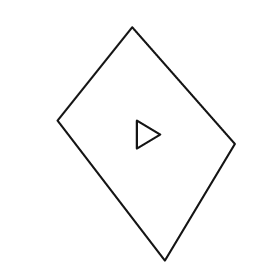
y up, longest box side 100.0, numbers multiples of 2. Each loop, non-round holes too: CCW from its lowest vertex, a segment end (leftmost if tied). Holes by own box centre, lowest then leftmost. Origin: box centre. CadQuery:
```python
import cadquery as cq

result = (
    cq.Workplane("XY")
    .moveTo(8.0, -50.0)
    .lineTo(38.0, 0.0)
    .lineTo(-6.0, 50.0)
    .lineTo(-38.0, 10.0)
    .close()
    .moveTo(-4.0, -2.0)
    .lineTo(6.0, 4.0)
    .lineTo(-4.0, 10.0)
    .close()
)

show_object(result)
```